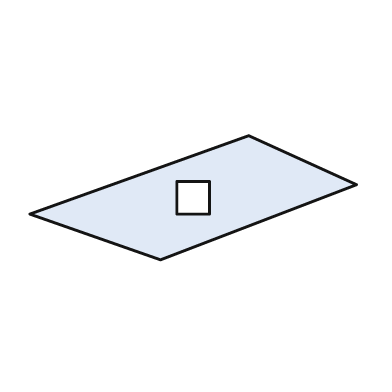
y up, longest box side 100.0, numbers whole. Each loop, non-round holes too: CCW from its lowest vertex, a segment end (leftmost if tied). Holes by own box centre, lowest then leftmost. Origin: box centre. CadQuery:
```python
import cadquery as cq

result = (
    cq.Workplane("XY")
    .moveTo(-10.0, -19.0)
    .lineTo(50.0, 4.0)
    .lineTo(17.0, 19.0)
    .lineTo(-50.0, -5.0)
    .close()
    .moveTo(-5.0, -5.0)
    .lineTo(5.0, -5.0)
    .lineTo(5.0, 5.0)
    .lineTo(-5.0, 5.0)
    .close()
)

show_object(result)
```